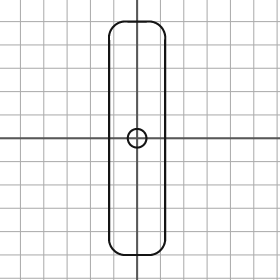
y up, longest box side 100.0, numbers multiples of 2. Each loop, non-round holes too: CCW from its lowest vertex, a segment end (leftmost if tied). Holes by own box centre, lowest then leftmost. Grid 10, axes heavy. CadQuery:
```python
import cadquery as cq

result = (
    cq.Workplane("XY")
    .moveTo(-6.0, -50.0)
    .lineTo(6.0, -50.0)
    .threePointArc((10.0, -48.0), (12.0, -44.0))
    .lineTo(12.0, 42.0)
    .threePointArc((10.0, 48.0), (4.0, 50.0))
    .lineTo(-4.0, 50.0)
    .threePointArc((-10.0, 48.0), (-12.0, 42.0))
    .lineTo(-12.0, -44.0)
    .threePointArc((-10.0, -48.0), (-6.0, -50.0))
    .close()
    .moveTo(0.0, 0.0)
    .circle(4.0)
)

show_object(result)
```